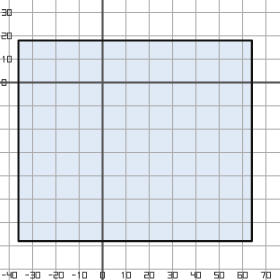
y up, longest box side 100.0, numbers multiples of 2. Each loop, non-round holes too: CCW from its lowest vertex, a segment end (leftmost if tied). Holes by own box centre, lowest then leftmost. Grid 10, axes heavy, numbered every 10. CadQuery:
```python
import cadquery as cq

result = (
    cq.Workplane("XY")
    .moveTo(-36.0, -68.0)
    .lineTo(64.0, -68.0)
    .lineTo(64.0, 18.0)
    .lineTo(-36.0, 18.0)
    .close()
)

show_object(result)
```